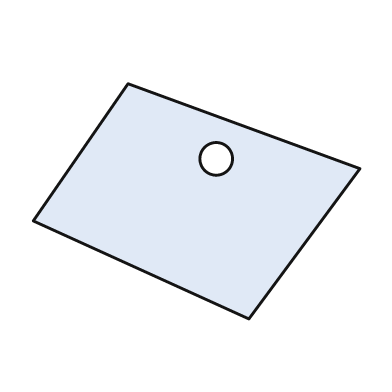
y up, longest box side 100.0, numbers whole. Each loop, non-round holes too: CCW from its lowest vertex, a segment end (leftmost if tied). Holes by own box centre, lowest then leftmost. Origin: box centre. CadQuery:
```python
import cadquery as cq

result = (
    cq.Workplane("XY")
    .moveTo(16.0, -36.0)
    .lineTo(50.0, 10.0)
    .lineTo(-21.0, 36.0)
    .lineTo(-50.0, -6.0)
    .close()
    .moveTo(6.0, 13.0)
    .circle(5.0)
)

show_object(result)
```